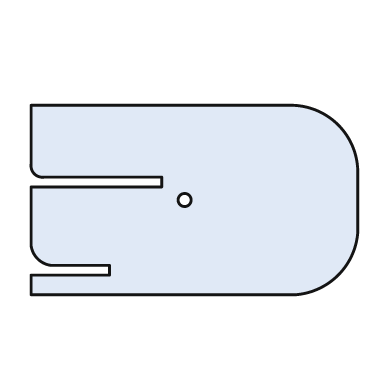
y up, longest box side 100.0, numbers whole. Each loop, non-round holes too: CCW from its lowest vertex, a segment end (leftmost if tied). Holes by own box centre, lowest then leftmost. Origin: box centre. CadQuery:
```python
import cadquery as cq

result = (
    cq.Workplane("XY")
    .moveTo(-50.0, -29.0)
    .lineTo(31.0, -29.0)
    .threePointArc((44.0, -23.0), (50.0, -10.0))
    .lineTo(50.0, 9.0)
    .threePointArc((44.0, 23.0), (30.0, 29.0))
    .lineTo(-50.0, 29.0)
    .lineTo(-50.0, 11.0)
    .threePointArc((-49.0, 8.0), (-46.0, 7.0))
    .lineTo(-10.0, 7.0)
    .lineTo(-10.0, 4.0)
    .lineTo(-50.0, 4.0)
    .lineTo(-50.0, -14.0)
    .threePointArc((-48.0, -18.0), (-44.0, -20.0))
    .lineTo(-26.0, -20.0)
    .lineTo(-26.0, -23.0)
    .lineTo(-50.0, -23.0)
    .close()
    .moveTo(-3.0, 0.0)
    .circle(2.0)
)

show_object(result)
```